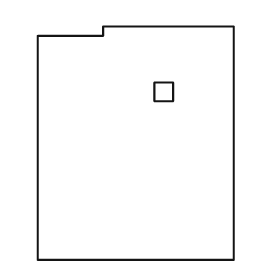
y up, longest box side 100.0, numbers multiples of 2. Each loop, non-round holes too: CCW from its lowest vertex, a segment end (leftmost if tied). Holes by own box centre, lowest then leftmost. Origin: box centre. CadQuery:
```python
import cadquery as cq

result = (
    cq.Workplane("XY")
    .moveTo(-42.0, -50.0)
    .lineTo(42.0, -50.0)
    .lineTo(42.0, 50.0)
    .lineTo(-14.0, 50.0)
    .lineTo(-14.0, 46.0)
    .lineTo(-42.0, 46.0)
    .close()
    .moveTo(8.0, 18.0)
    .lineTo(16.0, 18.0)
    .lineTo(16.0, 26.0)
    .lineTo(8.0, 26.0)
    .close()
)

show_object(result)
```